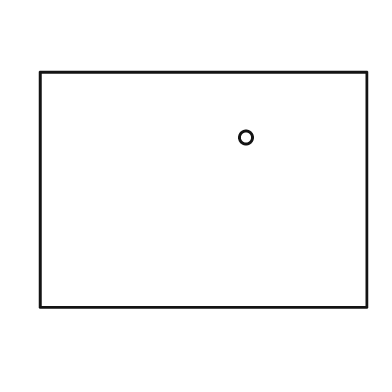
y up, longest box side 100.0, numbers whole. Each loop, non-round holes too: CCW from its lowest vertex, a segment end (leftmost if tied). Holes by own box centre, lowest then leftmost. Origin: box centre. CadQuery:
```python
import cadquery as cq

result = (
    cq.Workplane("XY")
    .moveTo(-50.0, -36.0)
    .lineTo(50.0, -36.0)
    .lineTo(50.0, 36.0)
    .lineTo(-50.0, 36.0)
    .close()
    .moveTo(13.0, 16.0)
    .circle(2.0)
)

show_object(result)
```